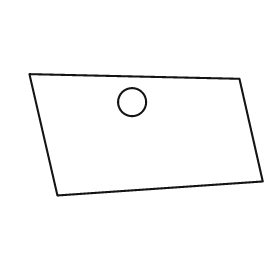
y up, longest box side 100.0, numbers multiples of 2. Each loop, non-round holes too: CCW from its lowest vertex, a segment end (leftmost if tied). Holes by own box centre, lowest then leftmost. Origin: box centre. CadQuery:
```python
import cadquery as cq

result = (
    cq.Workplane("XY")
    .moveTo(-38.0, -26.0)
    .lineTo(50.0, -20.0)
    .lineTo(40.0, 24.0)
    .lineTo(-50.0, 26.0)
    .close()
    .moveTo(-6.0, 14.0)
    .circle(6.0)
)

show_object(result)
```